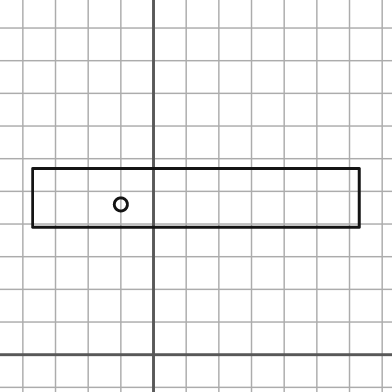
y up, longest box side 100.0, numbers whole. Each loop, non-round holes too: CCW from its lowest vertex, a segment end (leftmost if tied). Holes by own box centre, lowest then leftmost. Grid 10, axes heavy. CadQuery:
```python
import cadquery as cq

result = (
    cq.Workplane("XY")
    .moveTo(-37.0, 39.0)
    .lineTo(63.0, 39.0)
    .lineTo(63.0, 57.0)
    .lineTo(-37.0, 57.0)
    .close()
    .moveTo(-10.0, 46.0)
    .circle(2.0)
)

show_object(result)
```